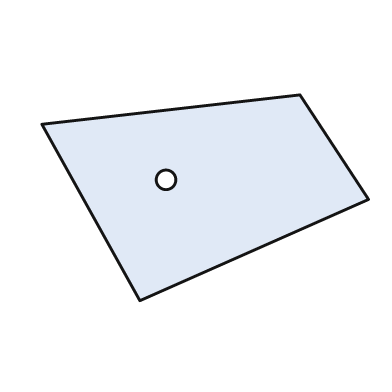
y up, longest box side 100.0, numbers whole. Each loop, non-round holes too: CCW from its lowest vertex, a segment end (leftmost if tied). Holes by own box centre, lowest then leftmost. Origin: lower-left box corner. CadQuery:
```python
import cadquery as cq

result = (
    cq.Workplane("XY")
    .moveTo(30.0, 0.0)
    .lineTo(100.0, 31.0)
    .lineTo(79.0, 63.0)
    .lineTo(0.0, 54.0)
    .close()
    .moveTo(38.0, 37.0)
    .circle(3.0)
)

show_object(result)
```